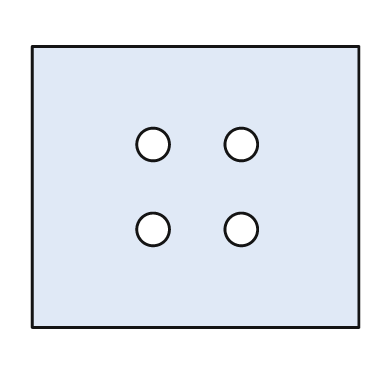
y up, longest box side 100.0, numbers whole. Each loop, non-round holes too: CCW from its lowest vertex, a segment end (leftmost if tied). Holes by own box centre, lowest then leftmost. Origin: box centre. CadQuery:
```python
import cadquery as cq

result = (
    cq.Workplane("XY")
    .moveTo(-50.0, -43.0)
    .lineTo(50.0, -43.0)
    .lineTo(50.0, 43.0)
    .lineTo(-50.0, 43.0)
    .close()
    .moveTo(-13.0, -13.0)
    .circle(5.0)
    .moveTo(14.0, -13.0)
    .circle(5.0)
    .moveTo(-13.0, 13.0)
    .circle(5.0)
    .moveTo(14.0, 13.0)
    .circle(5.0)
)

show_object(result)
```